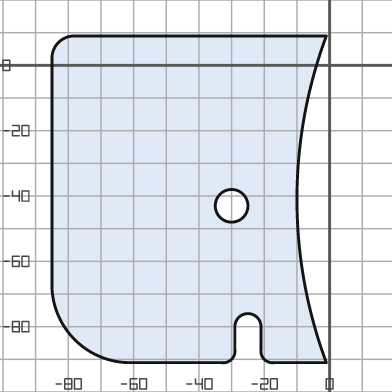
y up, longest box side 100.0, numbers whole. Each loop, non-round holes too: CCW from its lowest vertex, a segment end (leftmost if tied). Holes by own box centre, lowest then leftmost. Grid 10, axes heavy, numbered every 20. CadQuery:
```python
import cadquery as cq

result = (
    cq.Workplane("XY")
    .moveTo(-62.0, -91.0)
    .lineTo(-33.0, -91.0)
    .threePointArc((-30.0, -90.0), (-29.0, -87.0))
    .lineTo(-29.0, -80.0)
    .threePointArc((-25.0, -76.0), (-21.0, -80.0))
    .lineTo(-21.0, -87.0)
    .threePointArc((-20.0, -90.0), (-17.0, -91.0))
    .lineTo(-1.0, -91.0)
    .threePointArc((-10.0, -41.0), (-1.0, 9.0))
    .lineTo(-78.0, 9.0)
    .threePointArc((-83.0, 7.0), (-85.0, 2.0))
    .lineTo(-85.0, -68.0)
    .threePointArc((-78.0, -84.0), (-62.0, -91.0))
    .close()
    .moveTo(-30.0, -43.0)
    .circle(5.0)
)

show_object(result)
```